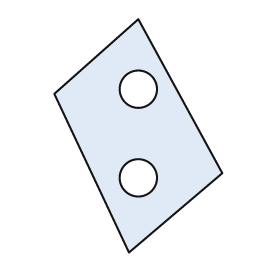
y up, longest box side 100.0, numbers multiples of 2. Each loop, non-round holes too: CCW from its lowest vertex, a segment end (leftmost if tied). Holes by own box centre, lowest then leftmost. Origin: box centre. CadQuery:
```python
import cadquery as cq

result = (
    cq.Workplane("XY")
    .moveTo(-4.0, -50.0)
    .lineTo(36.0, -16.0)
    .lineTo(0.0, 50.0)
    .lineTo(-36.0, 18.0)
    .close()
    .moveTo(0.0, -18.0)
    .circle(8.0)
    .moveTo(0.0, 20.0)
    .circle(8.0)
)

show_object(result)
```